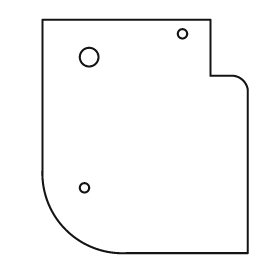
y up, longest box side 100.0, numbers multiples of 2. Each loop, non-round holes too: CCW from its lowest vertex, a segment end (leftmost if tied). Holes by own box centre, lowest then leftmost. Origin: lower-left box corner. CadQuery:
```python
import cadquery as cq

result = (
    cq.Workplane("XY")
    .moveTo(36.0, 0.0)
    .lineTo(88.0, 0.0)
    .lineTo(88.0, 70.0)
    .threePointArc((86.0, 74.0), (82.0, 76.0))
    .lineTo(72.0, 76.0)
    .lineTo(72.0, 100.0)
    .lineTo(0.0, 100.0)
    .lineTo(0.0, 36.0)
    .threePointArc((10.0, 10.0), (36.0, 0.0))
    .close()
    .moveTo(18.0, 28.0)
    .circle(2.0)
    .moveTo(20.0, 84.0)
    .circle(4.0)
    .moveTo(60.0, 94.0)
    .circle(2.0)
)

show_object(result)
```